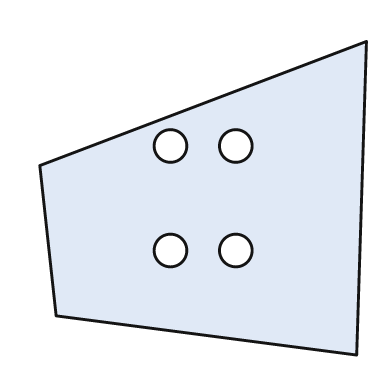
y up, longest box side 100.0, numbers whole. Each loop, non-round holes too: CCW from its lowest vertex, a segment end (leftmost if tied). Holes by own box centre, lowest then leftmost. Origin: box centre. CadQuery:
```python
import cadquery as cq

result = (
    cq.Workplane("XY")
    .moveTo(47.0, -48.0)
    .lineTo(50.0, 48.0)
    .lineTo(-50.0, 10.0)
    .lineTo(-45.0, -36.0)
    .close()
    .moveTo(-10.0, -16.0)
    .circle(5.0)
    .moveTo(10.0, -16.0)
    .circle(5.0)
    .moveTo(-10.0, 16.0)
    .circle(5.0)
    .moveTo(10.0, 16.0)
    .circle(5.0)
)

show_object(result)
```